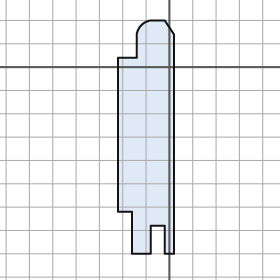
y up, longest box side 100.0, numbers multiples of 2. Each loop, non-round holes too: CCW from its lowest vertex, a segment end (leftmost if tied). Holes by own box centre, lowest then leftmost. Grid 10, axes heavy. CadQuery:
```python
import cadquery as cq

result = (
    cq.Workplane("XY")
    .moveTo(-16.0, -80.0)
    .lineTo(-8.0, -80.0)
    .lineTo(-8.0, -68.0)
    .lineTo(-2.0, -68.0)
    .lineTo(-2.0, -80.0)
    .lineTo(2.0, -80.0)
    .lineTo(2.0, 14.0)
    .lineTo(-2.0, 20.0)
    .lineTo(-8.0, 20.0)
    .threePointArc((-12.0, 18.0), (-14.0, 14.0))
    .lineTo(-14.0, 4.0)
    .lineTo(-22.0, 4.0)
    .lineTo(-22.0, -62.0)
    .lineTo(-16.0, -62.0)
    .close()
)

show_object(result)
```